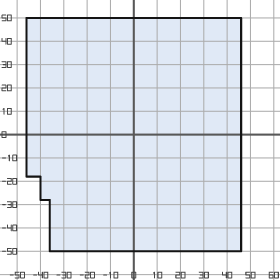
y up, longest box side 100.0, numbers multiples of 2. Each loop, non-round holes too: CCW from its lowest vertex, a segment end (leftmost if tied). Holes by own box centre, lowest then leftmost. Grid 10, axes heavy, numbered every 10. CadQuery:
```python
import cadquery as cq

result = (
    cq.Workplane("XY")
    .moveTo(-36.0, -50.0)
    .lineTo(46.0, -50.0)
    .lineTo(46.0, 50.0)
    .lineTo(-46.0, 50.0)
    .lineTo(-46.0, -18.0)
    .lineTo(-40.0, -18.0)
    .lineTo(-40.0, -28.0)
    .lineTo(-36.0, -28.0)
    .close()
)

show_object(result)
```